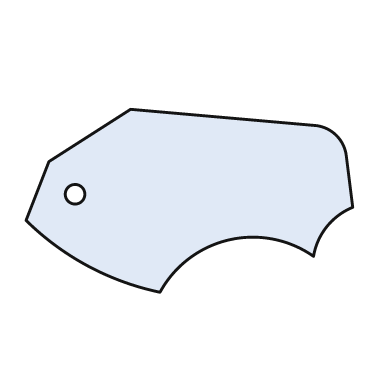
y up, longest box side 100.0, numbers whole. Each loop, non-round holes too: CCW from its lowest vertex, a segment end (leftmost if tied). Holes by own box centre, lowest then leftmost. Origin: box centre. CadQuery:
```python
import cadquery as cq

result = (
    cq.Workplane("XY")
    .moveTo(-9.0, -28.0)
    .threePointArc((12.0, -12.0), (38.0, -17.0))
    .threePointArc((42.0, -8.0), (50.0, -2.0))
    .lineTo(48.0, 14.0)
    .threePointArc((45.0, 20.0), (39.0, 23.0))
    .lineTo(-18.0, 28.0)
    .lineTo(-43.0, 12.0)
    .lineTo(-50.0, -6.0)
    .threePointArc((-31.0, -20.0), (-9.0, -28.0))
    .close()
    .moveTo(-35.0, 2.0)
    .circle(3.0)
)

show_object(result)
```